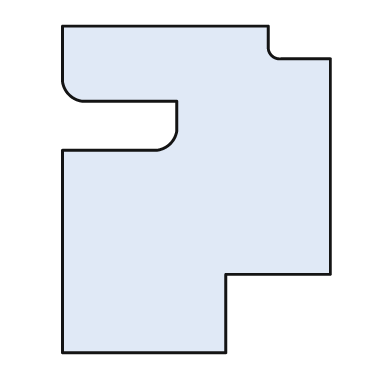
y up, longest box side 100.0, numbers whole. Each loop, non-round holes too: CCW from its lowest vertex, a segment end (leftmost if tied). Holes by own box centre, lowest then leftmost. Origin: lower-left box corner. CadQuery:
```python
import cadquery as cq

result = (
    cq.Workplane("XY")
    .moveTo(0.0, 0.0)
    .lineTo(50.0, 0.0)
    .lineTo(50.0, 24.0)
    .lineTo(82.0, 24.0)
    .lineTo(82.0, 90.0)
    .lineTo(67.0, 90.0)
    .threePointArc((64.0, 91.0), (63.0, 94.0))
    .lineTo(63.0, 100.0)
    .lineTo(0.0, 100.0)
    .lineTo(0.0, 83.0)
    .threePointArc((2.0, 79.0), (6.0, 77.0))
    .lineTo(35.0, 77.0)
    .lineTo(35.0, 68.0)
    .threePointArc((33.0, 64.0), (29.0, 62.0))
    .lineTo(0.0, 62.0)
    .close()
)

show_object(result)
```